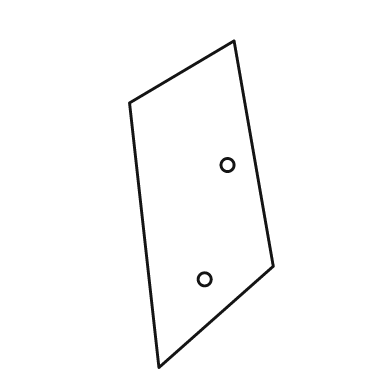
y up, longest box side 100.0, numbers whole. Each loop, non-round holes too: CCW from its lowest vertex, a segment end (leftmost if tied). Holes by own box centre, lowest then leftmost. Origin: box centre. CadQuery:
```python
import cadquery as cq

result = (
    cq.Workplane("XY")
    .moveTo(-13.0, -50.0)
    .lineTo(22.0, -19.0)
    .lineTo(10.0, 50.0)
    .lineTo(-22.0, 31.0)
    .close()
    .moveTo(1.0, -23.0)
    .circle(2.0)
    .moveTo(8.0, 12.0)
    .circle(2.0)
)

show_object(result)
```